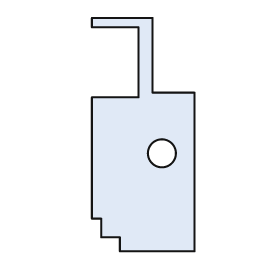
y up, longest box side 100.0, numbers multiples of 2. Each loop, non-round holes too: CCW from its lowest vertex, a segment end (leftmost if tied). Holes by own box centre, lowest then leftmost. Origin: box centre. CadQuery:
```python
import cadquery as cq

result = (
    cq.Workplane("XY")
    .moveTo(-10.0, -50.0)
    .lineTo(22.0, -50.0)
    .lineTo(22.0, 18.0)
    .lineTo(4.0, 18.0)
    .lineTo(4.0, 50.0)
    .lineTo(-22.0, 50.0)
    .lineTo(-22.0, 46.0)
    .lineTo(-2.0, 46.0)
    .lineTo(-2.0, 16.0)
    .lineTo(-22.0, 16.0)
    .lineTo(-22.0, -36.0)
    .lineTo(-18.0, -36.0)
    .lineTo(-18.0, -44.0)
    .lineTo(-10.0, -44.0)
    .close()
    .moveTo(8.0, -8.0)
    .circle(6.0)
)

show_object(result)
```